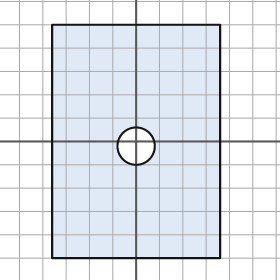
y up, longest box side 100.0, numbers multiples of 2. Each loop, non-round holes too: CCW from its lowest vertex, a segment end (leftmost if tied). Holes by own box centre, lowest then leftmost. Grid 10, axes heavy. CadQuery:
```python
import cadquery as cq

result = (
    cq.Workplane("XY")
    .moveTo(-36.0, -50.0)
    .lineTo(36.0, -50.0)
    .lineTo(36.0, 50.0)
    .lineTo(-36.0, 50.0)
    .close()
    .moveTo(0.0, -2.0)
    .circle(8.0)
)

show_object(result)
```